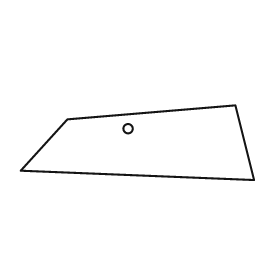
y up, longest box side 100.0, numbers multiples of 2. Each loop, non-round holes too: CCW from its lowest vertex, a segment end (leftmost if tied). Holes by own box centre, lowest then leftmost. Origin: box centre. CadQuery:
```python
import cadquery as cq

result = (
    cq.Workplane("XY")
    .moveTo(50.0, -16.0)
    .lineTo(42.0, 16.0)
    .lineTo(-30.0, 10.0)
    .lineTo(-50.0, -12.0)
    .close()
    .moveTo(-4.0, 6.0)
    .circle(2.0)
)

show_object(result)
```